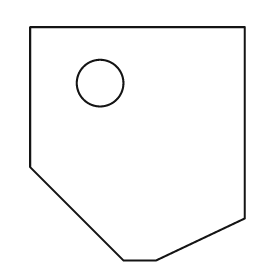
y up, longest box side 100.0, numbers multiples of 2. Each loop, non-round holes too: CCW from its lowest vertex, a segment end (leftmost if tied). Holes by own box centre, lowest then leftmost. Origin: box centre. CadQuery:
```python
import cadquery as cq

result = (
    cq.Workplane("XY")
    .moveTo(-6.0, -50.0)
    .lineTo(8.0, -50.0)
    .lineTo(46.0, -32.0)
    .lineTo(46.0, 50.0)
    .lineTo(-46.0, 50.0)
    .lineTo(-46.0, -10.0)
    .close()
    .moveTo(-16.0, 26.0)
    .circle(10.0)
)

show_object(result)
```